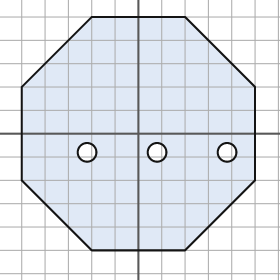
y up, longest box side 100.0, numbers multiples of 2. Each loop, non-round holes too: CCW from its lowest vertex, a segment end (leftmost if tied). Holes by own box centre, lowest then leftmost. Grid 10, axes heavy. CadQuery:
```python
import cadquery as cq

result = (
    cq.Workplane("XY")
    .moveTo(-20.0, -50.0)
    .lineTo(20.0, -50.0)
    .lineTo(50.0, -20.0)
    .lineTo(50.0, 20.0)
    .lineTo(20.0, 50.0)
    .lineTo(-20.0, 50.0)
    .lineTo(-50.0, 20.0)
    .lineTo(-50.0, -20.0)
    .close()
    .moveTo(-22.0, -8.0)
    .circle(4.0)
    .moveTo(8.0, -8.0)
    .circle(4.0)
    .moveTo(38.0, -8.0)
    .circle(4.0)
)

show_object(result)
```